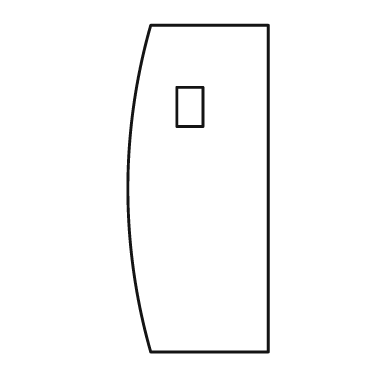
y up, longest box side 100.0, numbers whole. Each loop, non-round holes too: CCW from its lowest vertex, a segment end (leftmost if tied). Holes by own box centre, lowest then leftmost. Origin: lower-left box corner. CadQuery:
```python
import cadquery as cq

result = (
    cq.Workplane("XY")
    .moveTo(7.0, 0.0)
    .lineTo(43.0, 0.0)
    .lineTo(43.0, 100.0)
    .lineTo(7.0, 100.0)
    .threePointArc((0.0, 50.0), (7.0, 0.0))
    .close()
    .moveTo(15.0, 69.0)
    .lineTo(23.0, 69.0)
    .lineTo(23.0, 81.0)
    .lineTo(15.0, 81.0)
    .close()
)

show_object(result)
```